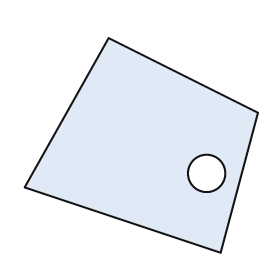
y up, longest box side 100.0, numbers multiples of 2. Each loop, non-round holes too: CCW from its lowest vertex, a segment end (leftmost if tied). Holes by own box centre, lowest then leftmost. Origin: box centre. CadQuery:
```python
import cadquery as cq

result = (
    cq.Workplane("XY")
    .moveTo(34.0, -46.0)
    .lineTo(50.0, 14.0)
    .lineTo(-14.0, 46.0)
    .lineTo(-50.0, -18.0)
    .close()
    .moveTo(28.0, -12.0)
    .circle(8.0)
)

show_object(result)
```